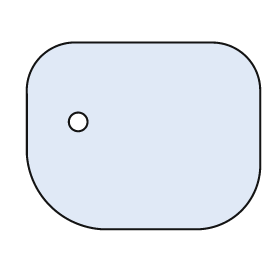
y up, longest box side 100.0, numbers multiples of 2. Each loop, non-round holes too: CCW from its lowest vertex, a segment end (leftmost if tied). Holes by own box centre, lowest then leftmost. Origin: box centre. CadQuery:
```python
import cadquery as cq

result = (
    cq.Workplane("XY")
    .moveTo(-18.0, -40.0)
    .lineTo(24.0, -40.0)
    .threePointArc((42.0, -32.0), (50.0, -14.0))
    .lineTo(50.0, 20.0)
    .threePointArc((44.0, 34.0), (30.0, 40.0))
    .lineTo(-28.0, 40.0)
    .threePointArc((-44.0, 34.0), (-50.0, 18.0))
    .lineTo(-50.0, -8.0)
    .threePointArc((-40.0, -30.0), (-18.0, -40.0))
    .close()
    .moveTo(-28.0, 6.0)
    .circle(4.0)
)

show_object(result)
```